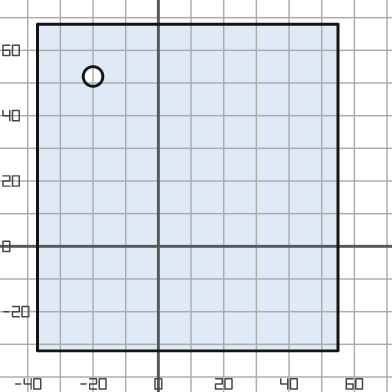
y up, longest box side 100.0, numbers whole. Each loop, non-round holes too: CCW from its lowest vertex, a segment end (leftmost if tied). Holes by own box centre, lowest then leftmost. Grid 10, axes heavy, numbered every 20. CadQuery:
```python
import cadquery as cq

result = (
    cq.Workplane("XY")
    .moveTo(-37.0, -32.0)
    .lineTo(55.0, -32.0)
    .lineTo(55.0, 68.0)
    .lineTo(-37.0, 68.0)
    .close()
    .moveTo(-20.0, 52.0)
    .circle(3.0)
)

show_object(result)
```